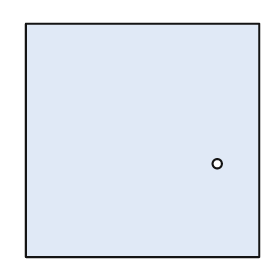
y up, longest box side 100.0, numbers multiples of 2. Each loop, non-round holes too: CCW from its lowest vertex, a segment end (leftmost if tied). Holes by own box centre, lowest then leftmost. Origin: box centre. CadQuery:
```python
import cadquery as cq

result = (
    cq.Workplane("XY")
    .moveTo(-50.0, -50.0)
    .lineTo(50.0, -50.0)
    .lineTo(50.0, 50.0)
    .lineTo(-50.0, 50.0)
    .close()
    .moveTo(32.0, -10.0)
    .circle(2.0)
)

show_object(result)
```